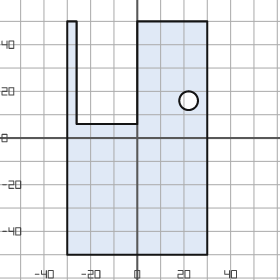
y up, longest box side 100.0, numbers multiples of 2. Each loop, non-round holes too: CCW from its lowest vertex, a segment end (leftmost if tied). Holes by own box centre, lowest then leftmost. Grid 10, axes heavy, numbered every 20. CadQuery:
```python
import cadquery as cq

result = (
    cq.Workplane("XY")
    .moveTo(-30.0, -50.0)
    .lineTo(30.0, -50.0)
    .lineTo(30.0, 50.0)
    .lineTo(0.0, 50.0)
    .lineTo(0.0, 6.0)
    .lineTo(-26.0, 6.0)
    .lineTo(-26.0, 50.0)
    .lineTo(-30.0, 50.0)
    .close()
    .moveTo(22.0, 16.0)
    .circle(4.0)
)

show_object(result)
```